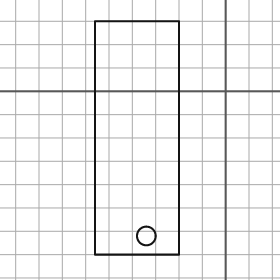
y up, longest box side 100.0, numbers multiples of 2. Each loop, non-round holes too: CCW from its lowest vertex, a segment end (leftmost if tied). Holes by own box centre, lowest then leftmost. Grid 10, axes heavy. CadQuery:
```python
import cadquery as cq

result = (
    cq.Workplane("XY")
    .moveTo(-56.0, -70.0)
    .lineTo(-20.0, -70.0)
    .lineTo(-20.0, 30.0)
    .lineTo(-56.0, 30.0)
    .close()
    .moveTo(-34.0, -62.0)
    .circle(4.0)
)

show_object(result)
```